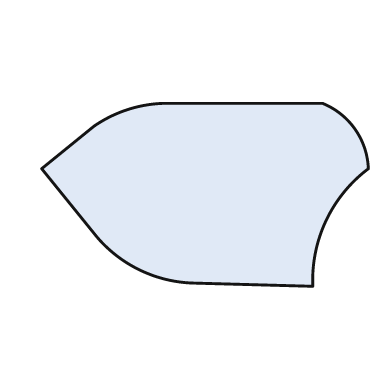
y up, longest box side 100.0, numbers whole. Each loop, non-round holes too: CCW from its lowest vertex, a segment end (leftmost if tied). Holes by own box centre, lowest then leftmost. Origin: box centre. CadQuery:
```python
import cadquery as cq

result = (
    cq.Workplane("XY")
    .moveTo(33.0, -28.0)
    .threePointArc((37.0, -8.0), (50.0, 8.0))
    .threePointArc((46.0, 20.0), (36.0, 28.0))
    .lineTo(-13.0, 28.0)
    .threePointArc((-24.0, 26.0), (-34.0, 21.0))
    .lineTo(-50.0, 8.0)
    .lineTo(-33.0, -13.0)
    .threePointArc((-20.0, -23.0), (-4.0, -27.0))
    .close()
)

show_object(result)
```